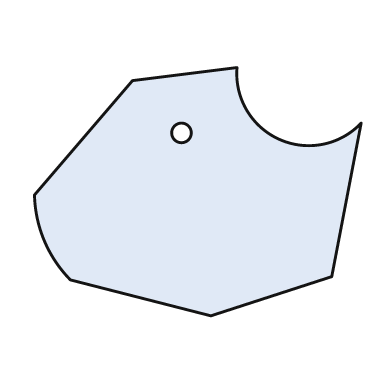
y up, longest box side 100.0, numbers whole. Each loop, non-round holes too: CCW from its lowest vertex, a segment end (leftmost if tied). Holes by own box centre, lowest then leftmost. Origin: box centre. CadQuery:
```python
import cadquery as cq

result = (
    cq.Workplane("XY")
    .moveTo(4.0, -38.0)
    .lineTo(41.0, -26.0)
    .lineTo(50.0, 21.0)
    .threePointArc((25.0, 16.0), (12.0, 38.0))
    .lineTo(-20.0, 34.0)
    .lineTo(-50.0, -1.0)
    .threePointArc((-47.0, -15.0), (-39.0, -27.0))
    .close()
    .moveTo(-5.0, 18.0)
    .circle(3.0)
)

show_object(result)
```